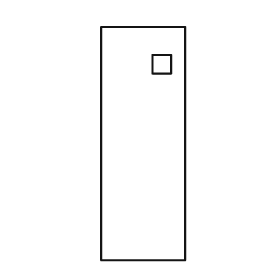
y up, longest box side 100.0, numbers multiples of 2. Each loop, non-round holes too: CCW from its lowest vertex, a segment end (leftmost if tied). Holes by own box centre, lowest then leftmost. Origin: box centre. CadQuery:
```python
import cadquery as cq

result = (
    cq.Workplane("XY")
    .moveTo(-18.0, -50.0)
    .lineTo(18.0, -50.0)
    .lineTo(18.0, 50.0)
    .lineTo(-18.0, 50.0)
    .close()
    .moveTo(4.0, 30.0)
    .lineTo(12.0, 30.0)
    .lineTo(12.0, 38.0)
    .lineTo(4.0, 38.0)
    .close()
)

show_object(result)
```